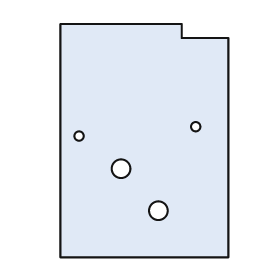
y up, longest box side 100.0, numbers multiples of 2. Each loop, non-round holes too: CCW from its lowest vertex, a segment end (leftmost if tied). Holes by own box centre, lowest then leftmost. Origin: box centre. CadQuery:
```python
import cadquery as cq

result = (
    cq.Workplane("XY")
    .moveTo(-36.0, -50.0)
    .lineTo(36.0, -50.0)
    .lineTo(36.0, 44.0)
    .lineTo(16.0, 44.0)
    .lineTo(16.0, 50.0)
    .lineTo(-36.0, 50.0)
    .close()
    .moveTo(6.0, -30.0)
    .circle(4.0)
    .moveTo(-10.0, -12.0)
    .circle(4.0)
    .moveTo(-28.0, 2.0)
    .circle(2.0)
    .moveTo(22.0, 6.0)
    .circle(2.0)
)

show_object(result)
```